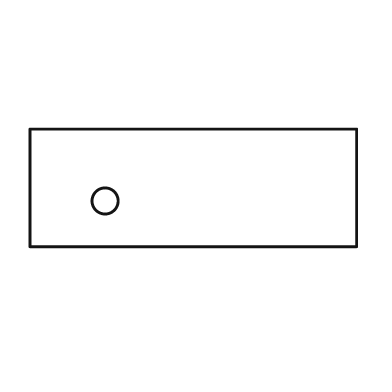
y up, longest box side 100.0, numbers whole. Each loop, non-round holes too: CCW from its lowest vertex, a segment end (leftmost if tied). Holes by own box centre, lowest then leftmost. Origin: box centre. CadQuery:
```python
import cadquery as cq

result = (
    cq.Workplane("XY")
    .moveTo(-50.0, -18.0)
    .lineTo(50.0, -18.0)
    .lineTo(50.0, 18.0)
    .lineTo(-50.0, 18.0)
    .close()
    .moveTo(-27.0, -4.0)
    .circle(4.0)
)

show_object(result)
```